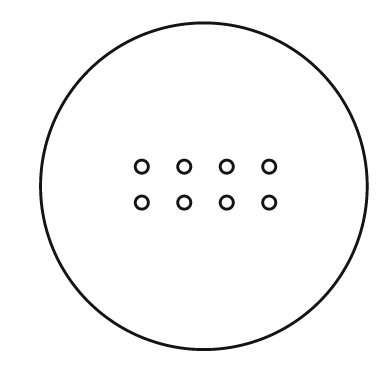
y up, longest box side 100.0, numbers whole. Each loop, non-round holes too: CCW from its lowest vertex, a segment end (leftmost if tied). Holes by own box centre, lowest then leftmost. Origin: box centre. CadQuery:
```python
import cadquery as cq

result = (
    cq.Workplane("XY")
    .moveTo(0.0, 0.0)
    .circle(50.0)
    .moveTo(-19.0, -5.0)
    .circle(2.0)
    .moveTo(-6.0, -5.0)
    .circle(2.0)
    .moveTo(7.0, -5.0)
    .circle(2.0)
    .moveTo(20.0, -5.0)
    .circle(2.0)
    .moveTo(-19.0, 6.0)
    .circle(2.0)
    .moveTo(-6.0, 6.0)
    .circle(2.0)
    .moveTo(7.0, 6.0)
    .circle(2.0)
    .moveTo(20.0, 6.0)
    .circle(2.0)
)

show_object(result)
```